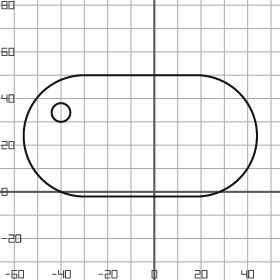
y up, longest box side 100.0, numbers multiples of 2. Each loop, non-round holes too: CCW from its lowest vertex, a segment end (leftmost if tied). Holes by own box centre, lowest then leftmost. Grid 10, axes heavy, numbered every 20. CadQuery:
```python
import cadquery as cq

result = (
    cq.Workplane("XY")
    .moveTo(-30.0, -2.0)
    .lineTo(18.0, -2.0)
    .threePointArc((44.0, 24.0), (18.0, 50.0))
    .lineTo(-30.0, 50.0)
    .threePointArc((-56.0, 24.0), (-30.0, -2.0))
    .close()
    .moveTo(-40.0, 34.0)
    .circle(4.0)
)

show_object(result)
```